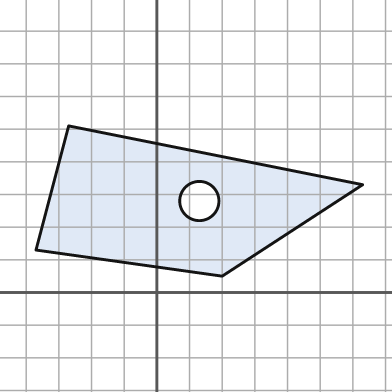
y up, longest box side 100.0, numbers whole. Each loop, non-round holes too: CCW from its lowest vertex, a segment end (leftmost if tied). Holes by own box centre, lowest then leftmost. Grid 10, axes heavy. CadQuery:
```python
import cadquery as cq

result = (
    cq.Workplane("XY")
    .moveTo(20.0, 5.0)
    .lineTo(63.0, 33.0)
    .lineTo(-27.0, 51.0)
    .lineTo(-37.0, 13.0)
    .close()
    .moveTo(13.0, 28.0)
    .circle(6.0)
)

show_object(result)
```